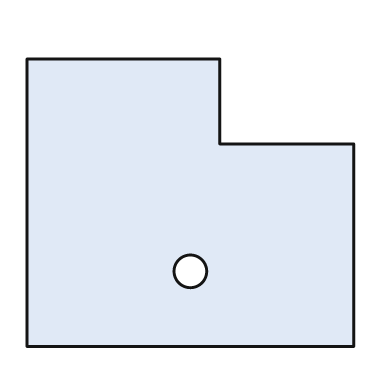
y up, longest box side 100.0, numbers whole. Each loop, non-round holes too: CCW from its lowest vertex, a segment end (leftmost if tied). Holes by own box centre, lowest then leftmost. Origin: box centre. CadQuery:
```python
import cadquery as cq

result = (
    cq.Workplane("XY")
    .moveTo(-50.0, -44.0)
    .lineTo(50.0, -44.0)
    .lineTo(50.0, 18.0)
    .lineTo(9.0, 18.0)
    .lineTo(9.0, 44.0)
    .lineTo(-50.0, 44.0)
    .close()
    .moveTo(0.0, -21.0)
    .circle(5.0)
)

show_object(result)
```